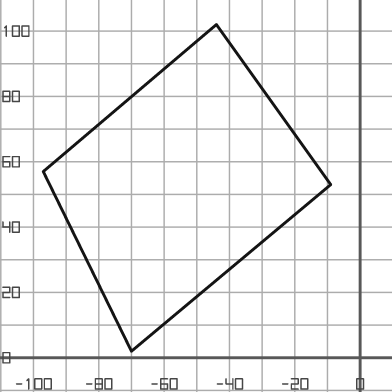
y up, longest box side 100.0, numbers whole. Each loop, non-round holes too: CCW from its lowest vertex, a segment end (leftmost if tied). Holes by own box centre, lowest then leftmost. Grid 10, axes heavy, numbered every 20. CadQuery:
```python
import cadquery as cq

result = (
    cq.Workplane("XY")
    .moveTo(-70.0, 2.0)
    .lineTo(-9.0, 53.0)
    .lineTo(-44.0, 102.0)
    .lineTo(-97.0, 57.0)
    .close()
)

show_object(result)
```